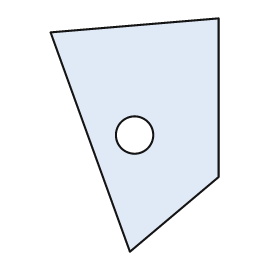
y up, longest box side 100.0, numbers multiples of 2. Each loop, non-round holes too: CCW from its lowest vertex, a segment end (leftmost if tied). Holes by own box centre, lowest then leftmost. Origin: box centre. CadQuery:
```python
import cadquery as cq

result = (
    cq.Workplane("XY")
    .moveTo(-2.0, -50.0)
    .lineTo(36.0, -18.0)
    .lineTo(36.0, 50.0)
    .lineTo(-36.0, 44.0)
    .close()
    .moveTo(0.0, 0.0)
    .circle(8.0)
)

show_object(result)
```